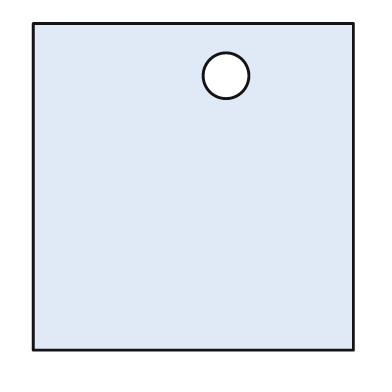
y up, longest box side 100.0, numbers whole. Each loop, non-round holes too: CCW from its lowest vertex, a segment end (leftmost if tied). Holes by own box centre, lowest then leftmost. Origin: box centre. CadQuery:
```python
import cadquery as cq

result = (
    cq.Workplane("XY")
    .moveTo(-49.0, -50.0)
    .lineTo(49.0, -50.0)
    .lineTo(49.0, 50.0)
    .lineTo(-49.0, 50.0)
    .close()
    .moveTo(10.0, 34.0)
    .circle(7.0)
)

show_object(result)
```